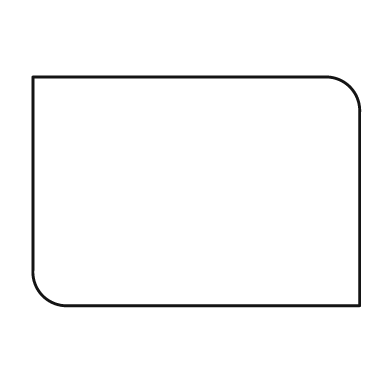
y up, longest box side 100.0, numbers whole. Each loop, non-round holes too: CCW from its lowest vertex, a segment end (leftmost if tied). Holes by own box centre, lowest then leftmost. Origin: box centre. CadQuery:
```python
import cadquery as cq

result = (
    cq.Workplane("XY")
    .moveTo(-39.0, -35.0)
    .lineTo(50.0, -35.0)
    .lineTo(50.0, 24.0)
    .threePointArc((47.0, 32.0), (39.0, 35.0))
    .lineTo(-50.0, 35.0)
    .lineTo(-50.0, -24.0)
    .threePointArc((-47.0, -32.0), (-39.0, -35.0))
    .close()
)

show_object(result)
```